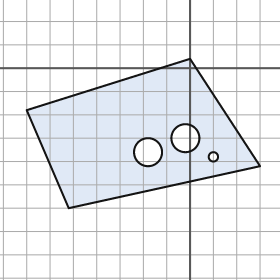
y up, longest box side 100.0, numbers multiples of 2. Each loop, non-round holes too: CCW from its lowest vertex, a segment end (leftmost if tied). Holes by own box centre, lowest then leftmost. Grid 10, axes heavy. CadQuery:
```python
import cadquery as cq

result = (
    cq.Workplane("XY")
    .moveTo(-52.0, -60.0)
    .lineTo(30.0, -42.0)
    .lineTo(0.0, 4.0)
    .lineTo(-70.0, -18.0)
    .close()
    .moveTo(10.0, -38.0)
    .circle(2.0)
    .moveTo(-18.0, -36.0)
    .circle(6.0)
    .moveTo(-2.0, -30.0)
    .circle(6.0)
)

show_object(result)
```